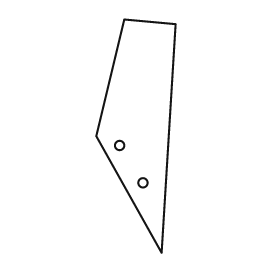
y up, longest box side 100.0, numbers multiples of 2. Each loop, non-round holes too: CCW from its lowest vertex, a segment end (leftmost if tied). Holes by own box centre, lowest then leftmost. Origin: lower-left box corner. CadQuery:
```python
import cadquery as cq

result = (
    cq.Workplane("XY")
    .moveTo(28.0, 0.0)
    .lineTo(34.0, 98.0)
    .lineTo(12.0, 100.0)
    .lineTo(0.0, 50.0)
    .close()
    .moveTo(20.0, 30.0)
    .circle(2.0)
    .moveTo(10.0, 46.0)
    .circle(2.0)
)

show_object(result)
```